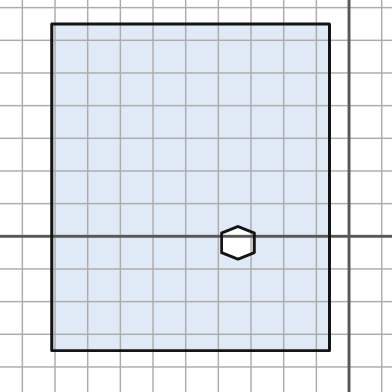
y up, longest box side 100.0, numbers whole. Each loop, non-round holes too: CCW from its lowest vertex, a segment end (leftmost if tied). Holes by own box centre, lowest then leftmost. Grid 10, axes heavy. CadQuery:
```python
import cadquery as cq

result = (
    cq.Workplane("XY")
    .moveTo(-91.0, -35.0)
    .lineTo(-6.0, -35.0)
    .lineTo(-6.0, 65.0)
    .lineTo(-91.0, 65.0)
    .close()
    .moveTo(-34.0, -7.0)
    .lineTo(-29.0, -5.0)
    .lineTo(-29.0, 1.0)
    .lineTo(-34.0, 3.0)
    .lineTo(-39.0, 1.0)
    .lineTo(-39.0, -5.0)
    .close()
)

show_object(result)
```